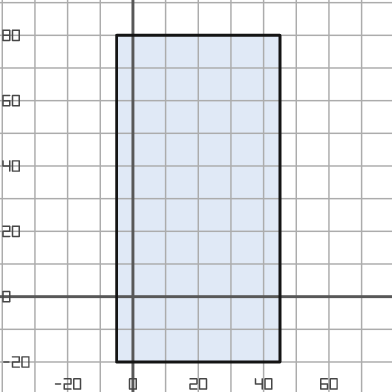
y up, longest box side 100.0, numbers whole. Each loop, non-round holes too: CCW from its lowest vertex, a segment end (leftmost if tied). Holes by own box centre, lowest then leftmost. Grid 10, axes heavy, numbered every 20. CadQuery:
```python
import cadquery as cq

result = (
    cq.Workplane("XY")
    .moveTo(-5.0, -20.0)
    .lineTo(45.0, -20.0)
    .lineTo(45.0, 80.0)
    .lineTo(-5.0, 80.0)
    .close()
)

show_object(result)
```